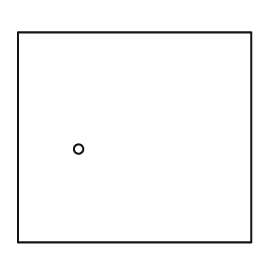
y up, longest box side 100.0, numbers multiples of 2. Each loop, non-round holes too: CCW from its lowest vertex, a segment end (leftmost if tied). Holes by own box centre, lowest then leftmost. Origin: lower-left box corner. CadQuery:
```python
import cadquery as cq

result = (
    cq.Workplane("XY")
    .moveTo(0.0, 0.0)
    .lineTo(100.0, 0.0)
    .lineTo(100.0, 90.0)
    .lineTo(0.0, 90.0)
    .close()
    .moveTo(26.0, 40.0)
    .circle(2.0)
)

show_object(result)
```